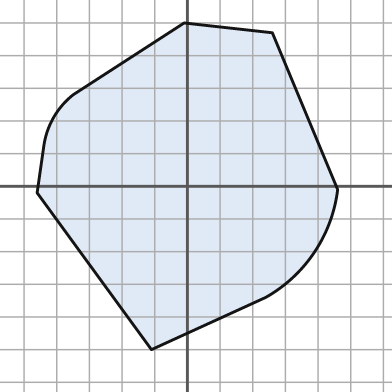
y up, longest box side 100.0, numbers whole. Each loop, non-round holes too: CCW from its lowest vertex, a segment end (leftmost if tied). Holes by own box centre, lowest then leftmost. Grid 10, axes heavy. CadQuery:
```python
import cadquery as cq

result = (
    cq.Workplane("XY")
    .moveTo(-11.0, -50.0)
    .lineTo(24.0, -34.0)
    .threePointArc((39.0, -20.0), (46.0, -1.0))
    .lineTo(26.0, 47.0)
    .lineTo(-1.0, 50.0)
    .lineTo(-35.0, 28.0)
    .threePointArc((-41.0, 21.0), (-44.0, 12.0))
    .lineTo(-46.0, -2.0)
    .close()
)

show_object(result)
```